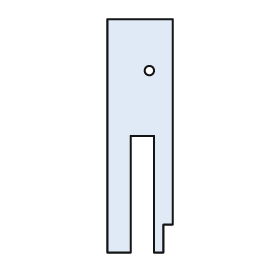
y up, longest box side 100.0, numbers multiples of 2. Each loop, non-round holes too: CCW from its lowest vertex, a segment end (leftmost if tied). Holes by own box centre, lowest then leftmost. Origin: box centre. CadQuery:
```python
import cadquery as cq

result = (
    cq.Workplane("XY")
    .moveTo(-14.0, -50.0)
    .lineTo(-4.0, -50.0)
    .lineTo(-4.0, 0.0)
    .lineTo(6.0, 0.0)
    .lineTo(6.0, -50.0)
    .lineTo(10.0, -50.0)
    .lineTo(10.0, -38.0)
    .lineTo(14.0, -38.0)
    .lineTo(14.0, 50.0)
    .lineTo(-14.0, 50.0)
    .close()
    .moveTo(4.0, 28.0)
    .circle(2.0)
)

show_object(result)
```